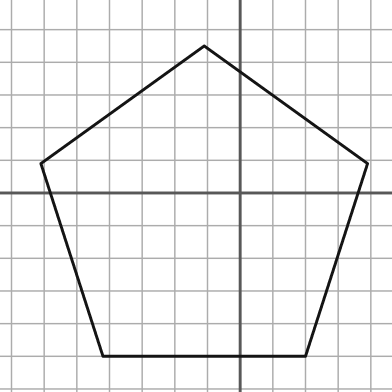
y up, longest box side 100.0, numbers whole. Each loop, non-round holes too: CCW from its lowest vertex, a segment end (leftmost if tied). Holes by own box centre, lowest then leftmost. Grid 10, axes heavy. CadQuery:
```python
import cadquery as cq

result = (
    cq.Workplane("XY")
    .moveTo(-42.0, -50.0)
    .lineTo(20.0, -50.0)
    .lineTo(39.0, 9.0)
    .lineTo(-11.0, 45.0)
    .lineTo(-61.0, 9.0)
    .close()
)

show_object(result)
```